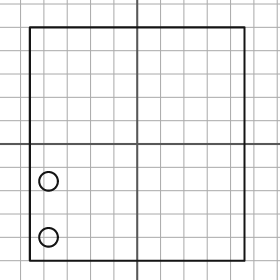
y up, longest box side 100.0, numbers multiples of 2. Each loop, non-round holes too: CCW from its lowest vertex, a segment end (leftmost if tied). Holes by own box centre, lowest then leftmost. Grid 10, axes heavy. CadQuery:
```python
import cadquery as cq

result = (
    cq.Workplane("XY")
    .moveTo(-46.0, -50.0)
    .lineTo(46.0, -50.0)
    .lineTo(46.0, 50.0)
    .lineTo(-46.0, 50.0)
    .close()
    .moveTo(-38.0, -40.0)
    .circle(4.0)
    .moveTo(-38.0, -16.0)
    .circle(4.0)
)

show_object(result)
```